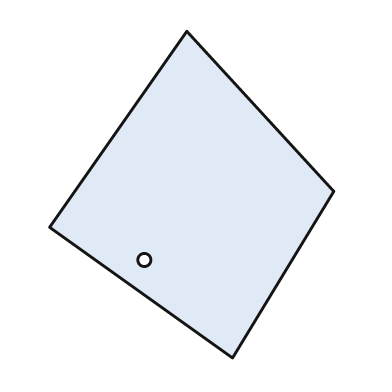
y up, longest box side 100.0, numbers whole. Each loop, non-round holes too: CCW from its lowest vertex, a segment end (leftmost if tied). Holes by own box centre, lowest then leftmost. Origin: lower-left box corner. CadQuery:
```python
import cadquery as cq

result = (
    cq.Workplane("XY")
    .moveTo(56.0, 0.0)
    .lineTo(87.0, 51.0)
    .lineTo(42.0, 100.0)
    .lineTo(0.0, 40.0)
    .close()
    .moveTo(29.0, 30.0)
    .circle(2.0)
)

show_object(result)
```